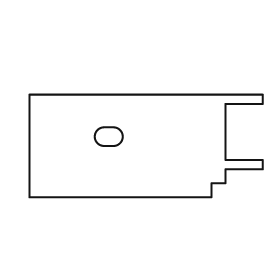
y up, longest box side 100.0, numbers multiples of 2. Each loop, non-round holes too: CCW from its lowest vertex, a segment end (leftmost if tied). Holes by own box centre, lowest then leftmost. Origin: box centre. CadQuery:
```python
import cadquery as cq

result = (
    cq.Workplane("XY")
    .moveTo(-50.0, -22.0)
    .lineTo(28.0, -22.0)
    .lineTo(28.0, -16.0)
    .lineTo(34.0, -16.0)
    .lineTo(34.0, -10.0)
    .lineTo(50.0, -10.0)
    .lineTo(50.0, -6.0)
    .lineTo(34.0, -6.0)
    .lineTo(34.0, 18.0)
    .lineTo(50.0, 18.0)
    .lineTo(50.0, 22.0)
    .lineTo(-50.0, 22.0)
    .close()
    .moveTo(-18.0, 0.0)
    .lineTo(-14.0, 0.0)
    .threePointArc((-10.0, 4.0), (-14.0, 8.0))
    .lineTo(-18.0, 8.0)
    .threePointArc((-22.0, 4.0), (-18.0, 0.0))
    .close()
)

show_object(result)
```